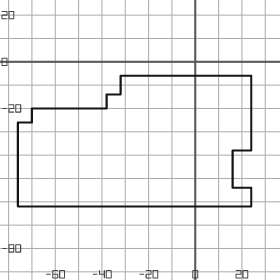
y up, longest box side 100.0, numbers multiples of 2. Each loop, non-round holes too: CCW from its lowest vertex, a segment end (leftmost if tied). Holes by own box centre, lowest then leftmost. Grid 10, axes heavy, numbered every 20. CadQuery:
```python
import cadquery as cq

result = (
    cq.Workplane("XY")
    .moveTo(-76.0, -62.0)
    .lineTo(24.0, -62.0)
    .lineTo(24.0, -54.0)
    .lineTo(16.0, -54.0)
    .lineTo(16.0, -38.0)
    .lineTo(24.0, -38.0)
    .lineTo(24.0, -6.0)
    .lineTo(-32.0, -6.0)
    .lineTo(-32.0, -14.0)
    .lineTo(-38.0, -14.0)
    .lineTo(-38.0, -20.0)
    .lineTo(-70.0, -20.0)
    .lineTo(-70.0, -26.0)
    .lineTo(-76.0, -26.0)
    .close()
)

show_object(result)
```